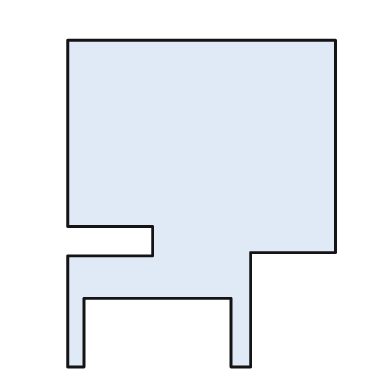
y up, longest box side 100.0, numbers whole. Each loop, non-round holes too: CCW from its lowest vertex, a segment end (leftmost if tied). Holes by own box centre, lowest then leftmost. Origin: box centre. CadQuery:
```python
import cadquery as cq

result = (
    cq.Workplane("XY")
    .moveTo(-41.0, -50.0)
    .lineTo(-36.0, -50.0)
    .lineTo(-36.0, -29.0)
    .lineTo(9.0, -29.0)
    .lineTo(9.0, -50.0)
    .lineTo(15.0, -50.0)
    .lineTo(15.0, -15.0)
    .lineTo(41.0, -15.0)
    .lineTo(41.0, 50.0)
    .lineTo(-41.0, 50.0)
    .lineTo(-41.0, -7.0)
    .lineTo(-15.0, -7.0)
    .lineTo(-15.0, -16.0)
    .lineTo(-41.0, -16.0)
    .close()
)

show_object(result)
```